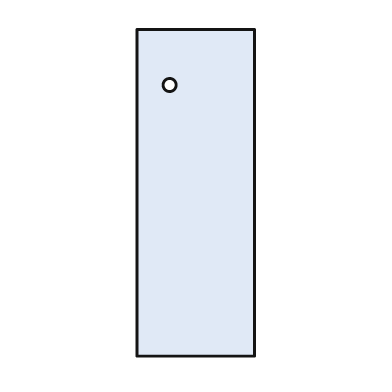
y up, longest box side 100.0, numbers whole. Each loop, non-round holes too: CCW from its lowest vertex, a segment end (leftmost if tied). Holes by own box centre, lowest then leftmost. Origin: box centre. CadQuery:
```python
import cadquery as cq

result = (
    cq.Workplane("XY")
    .moveTo(-18.0, -50.0)
    .lineTo(18.0, -50.0)
    .lineTo(18.0, 50.0)
    .lineTo(-18.0, 50.0)
    .close()
    .moveTo(-8.0, 33.0)
    .circle(2.0)
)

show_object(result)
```